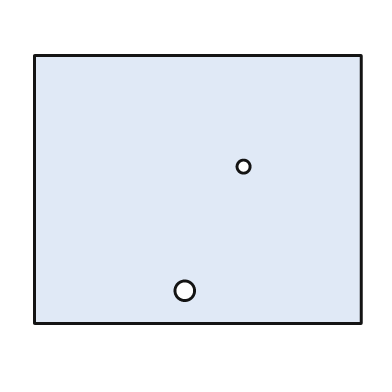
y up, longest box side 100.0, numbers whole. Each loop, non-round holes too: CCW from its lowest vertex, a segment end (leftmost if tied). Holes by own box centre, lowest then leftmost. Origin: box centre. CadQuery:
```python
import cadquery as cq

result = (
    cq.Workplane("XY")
    .moveTo(-50.0, -41.0)
    .lineTo(50.0, -41.0)
    .lineTo(50.0, 41.0)
    .lineTo(-50.0, 41.0)
    .close()
    .moveTo(-4.0, -31.0)
    .circle(3.0)
    .moveTo(14.0, 7.0)
    .circle(2.0)
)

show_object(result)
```